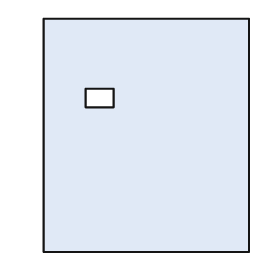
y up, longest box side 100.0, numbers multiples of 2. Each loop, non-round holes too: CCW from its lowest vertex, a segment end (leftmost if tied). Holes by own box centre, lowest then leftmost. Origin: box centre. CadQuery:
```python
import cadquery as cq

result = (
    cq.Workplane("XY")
    .moveTo(-44.0, -50.0)
    .lineTo(44.0, -50.0)
    .lineTo(44.0, 50.0)
    .lineTo(-44.0, 50.0)
    .close()
    .moveTo(-26.0, 12.0)
    .lineTo(-14.0, 12.0)
    .lineTo(-14.0, 20.0)
    .lineTo(-26.0, 20.0)
    .close()
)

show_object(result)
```